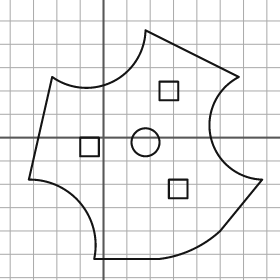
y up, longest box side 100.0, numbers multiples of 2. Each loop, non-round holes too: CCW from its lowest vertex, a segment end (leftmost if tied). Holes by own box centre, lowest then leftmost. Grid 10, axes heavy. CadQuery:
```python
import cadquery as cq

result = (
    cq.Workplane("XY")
    .moveTo(-4.0, -52.0)
    .lineTo(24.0, -52.0)
    .threePointArc((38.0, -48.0), (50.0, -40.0))
    .lineTo(68.0, -18.0)
    .threePointArc((46.0, 0.0), (58.0, 26.0))
    .lineTo(18.0, 46.0)
    .threePointArc((4.0, 24.0), (-22.0, 26.0))
    .lineTo(-32.0, -18.0)
    .threePointArc((-10.0, -28.0), (-4.0, -52.0))
    .close()
    .moveTo(28.0, -26.0)
    .lineTo(36.0, -26.0)
    .lineTo(36.0, -18.0)
    .lineTo(28.0, -18.0)
    .close()
    .moveTo(-10.0, -8.0)
    .lineTo(-2.0, -8.0)
    .lineTo(-2.0, 0.0)
    .lineTo(-10.0, 0.0)
    .close()
    .moveTo(18.0, -2.0)
    .circle(6.0)
    .moveTo(24.0, 16.0)
    .lineTo(32.0, 16.0)
    .lineTo(32.0, 24.0)
    .lineTo(24.0, 24.0)
    .close()
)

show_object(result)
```